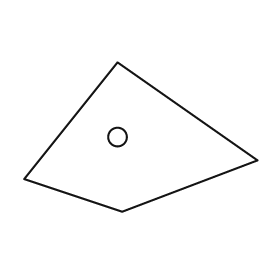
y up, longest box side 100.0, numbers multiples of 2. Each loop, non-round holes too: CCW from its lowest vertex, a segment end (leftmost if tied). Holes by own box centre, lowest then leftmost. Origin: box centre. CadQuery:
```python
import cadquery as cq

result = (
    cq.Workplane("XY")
    .moveTo(-8.0, -32.0)
    .lineTo(50.0, -10.0)
    .lineTo(-10.0, 32.0)
    .lineTo(-50.0, -18.0)
    .close()
    .moveTo(-10.0, 0.0)
    .circle(4.0)
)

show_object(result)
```